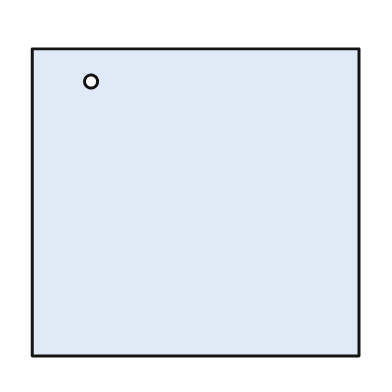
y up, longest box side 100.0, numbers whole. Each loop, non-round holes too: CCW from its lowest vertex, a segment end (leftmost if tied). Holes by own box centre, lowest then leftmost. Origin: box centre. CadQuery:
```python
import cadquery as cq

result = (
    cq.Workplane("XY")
    .moveTo(-50.0, -47.0)
    .lineTo(50.0, -47.0)
    .lineTo(50.0, 47.0)
    .lineTo(-50.0, 47.0)
    .close()
    .moveTo(-32.0, 37.0)
    .circle(2.0)
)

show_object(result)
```